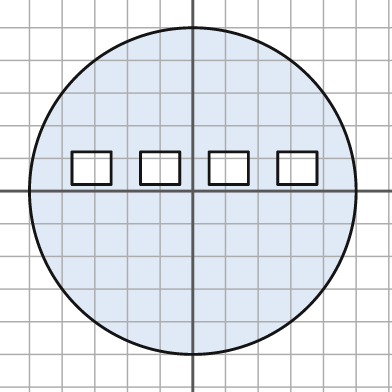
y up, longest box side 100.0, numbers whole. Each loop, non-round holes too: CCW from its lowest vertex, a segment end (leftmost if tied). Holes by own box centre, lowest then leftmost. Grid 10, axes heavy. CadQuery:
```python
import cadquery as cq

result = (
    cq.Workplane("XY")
    .moveTo(0.0, 0.0)
    .circle(50.0)
    .moveTo(-37.0, 2.0)
    .lineTo(-25.0, 2.0)
    .lineTo(-25.0, 12.0)
    .lineTo(-37.0, 12.0)
    .close()
    .moveTo(-16.0, 2.0)
    .lineTo(-4.0, 2.0)
    .lineTo(-4.0, 12.0)
    .lineTo(-16.0, 12.0)
    .close()
    .moveTo(5.0, 2.0)
    .lineTo(17.0, 2.0)
    .lineTo(17.0, 12.0)
    .lineTo(5.0, 12.0)
    .close()
    .moveTo(26.0, 2.0)
    .lineTo(38.0, 2.0)
    .lineTo(38.0, 12.0)
    .lineTo(26.0, 12.0)
    .close()
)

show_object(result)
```